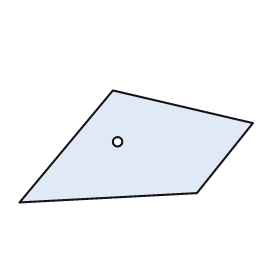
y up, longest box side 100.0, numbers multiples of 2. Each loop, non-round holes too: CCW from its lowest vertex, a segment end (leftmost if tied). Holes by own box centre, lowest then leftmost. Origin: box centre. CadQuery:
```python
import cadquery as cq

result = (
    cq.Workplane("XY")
    .moveTo(-50.0, -24.0)
    .lineTo(26.0, -20.0)
    .lineTo(50.0, 10.0)
    .lineTo(-10.0, 24.0)
    .close()
    .moveTo(-8.0, 2.0)
    .circle(2.0)
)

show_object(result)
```